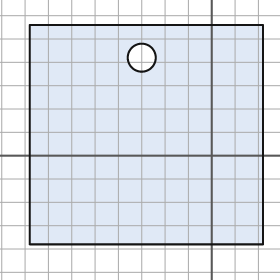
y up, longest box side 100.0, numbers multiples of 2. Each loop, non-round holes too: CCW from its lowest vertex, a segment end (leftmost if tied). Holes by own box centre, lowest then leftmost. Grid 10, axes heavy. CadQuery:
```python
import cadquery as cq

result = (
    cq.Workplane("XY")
    .moveTo(-78.0, -38.0)
    .lineTo(22.0, -38.0)
    .lineTo(22.0, 56.0)
    .lineTo(-78.0, 56.0)
    .close()
    .moveTo(-30.0, 42.0)
    .circle(6.0)
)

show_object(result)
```